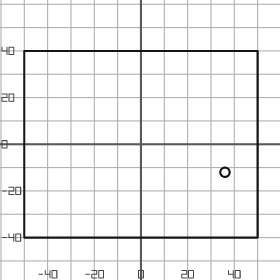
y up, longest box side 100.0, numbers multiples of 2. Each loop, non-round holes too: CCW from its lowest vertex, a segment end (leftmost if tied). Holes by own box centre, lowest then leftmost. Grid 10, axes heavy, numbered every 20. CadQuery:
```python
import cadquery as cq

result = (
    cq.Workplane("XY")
    .moveTo(-50.0, -40.0)
    .lineTo(50.0, -40.0)
    .lineTo(50.0, 40.0)
    .lineTo(-50.0, 40.0)
    .close()
    .moveTo(36.0, -12.0)
    .circle(2.0)
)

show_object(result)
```